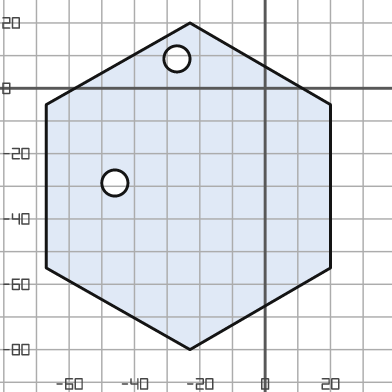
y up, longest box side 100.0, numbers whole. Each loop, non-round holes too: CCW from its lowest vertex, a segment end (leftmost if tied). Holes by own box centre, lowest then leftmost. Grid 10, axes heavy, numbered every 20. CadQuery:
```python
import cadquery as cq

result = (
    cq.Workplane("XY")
    .moveTo(-23.0, -80.0)
    .lineTo(20.0, -55.0)
    .lineTo(20.0, -5.0)
    .lineTo(-23.0, 20.0)
    .lineTo(-67.0, -5.0)
    .lineTo(-67.0, -55.0)
    .close()
    .moveTo(-46.0, -29.0)
    .circle(4.0)
    .moveTo(-27.0, 9.0)
    .circle(4.0)
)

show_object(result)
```